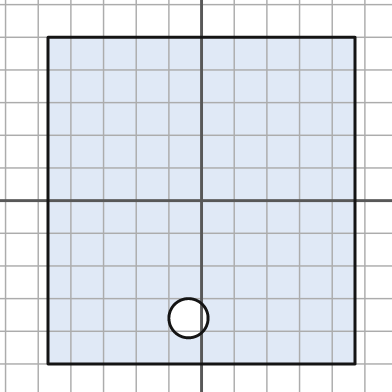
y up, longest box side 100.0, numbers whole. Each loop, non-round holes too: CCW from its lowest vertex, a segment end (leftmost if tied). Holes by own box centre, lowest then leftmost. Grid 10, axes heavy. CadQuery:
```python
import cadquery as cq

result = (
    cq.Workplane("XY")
    .moveTo(-47.0, -50.0)
    .lineTo(47.0, -50.0)
    .lineTo(47.0, 50.0)
    .lineTo(-47.0, 50.0)
    .close()
    .moveTo(-4.0, -36.0)
    .circle(6.0)
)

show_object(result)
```